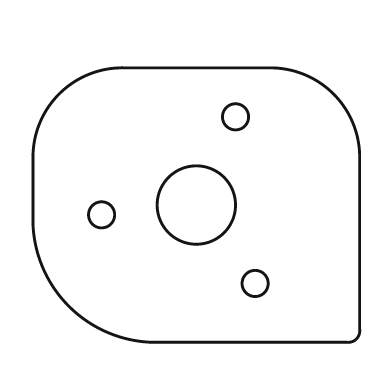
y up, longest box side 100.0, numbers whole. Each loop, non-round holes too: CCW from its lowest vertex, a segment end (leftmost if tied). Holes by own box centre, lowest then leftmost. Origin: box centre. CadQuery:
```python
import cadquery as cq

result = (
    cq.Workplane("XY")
    .moveTo(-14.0, -42.0)
    .lineTo(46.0, -42.0)
    .threePointArc((49.0, -41.0), (50.0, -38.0))
    .lineTo(50.0, 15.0)
    .threePointArc((42.0, 34.0), (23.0, 42.0))
    .lineTo(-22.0, 42.0)
    .threePointArc((-42.0, 34.0), (-50.0, 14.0))
    .lineTo(-50.0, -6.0)
    .threePointArc((-39.0, -31.0), (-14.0, -42.0))
    .close()
    .moveTo(18.0, -24.0)
    .circle(4.0)
    .moveTo(-29.0, -3.0)
    .circle(4.0)
    .moveTo(0.0, 0.0)
    .circle(12.0)
    .moveTo(12.0, 27.0)
    .circle(4.0)
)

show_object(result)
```